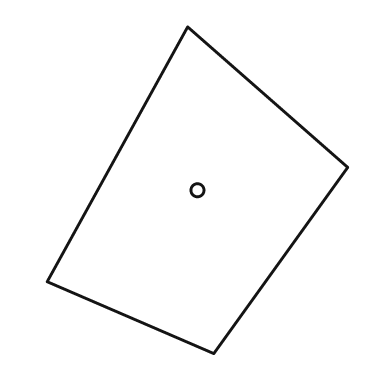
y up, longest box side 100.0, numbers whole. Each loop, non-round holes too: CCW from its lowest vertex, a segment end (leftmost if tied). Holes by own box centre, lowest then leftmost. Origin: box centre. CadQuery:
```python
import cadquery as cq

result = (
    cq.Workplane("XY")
    .moveTo(5.0, -50.0)
    .lineTo(46.0, 7.0)
    .lineTo(-3.0, 50.0)
    .lineTo(-46.0, -28.0)
    .close()
    .moveTo(0.0, 0.0)
    .circle(2.0)
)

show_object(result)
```